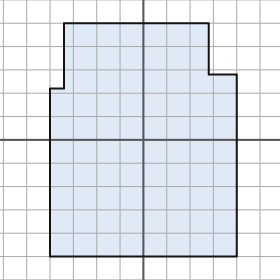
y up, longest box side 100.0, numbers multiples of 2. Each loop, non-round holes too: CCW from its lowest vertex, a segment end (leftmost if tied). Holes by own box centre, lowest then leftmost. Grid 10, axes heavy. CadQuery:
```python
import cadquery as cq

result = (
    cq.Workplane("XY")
    .moveTo(-40.0, -50.0)
    .lineTo(40.0, -50.0)
    .lineTo(40.0, 28.0)
    .lineTo(28.0, 28.0)
    .lineTo(28.0, 50.0)
    .lineTo(-34.0, 50.0)
    .lineTo(-34.0, 22.0)
    .lineTo(-40.0, 22.0)
    .close()
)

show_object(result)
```